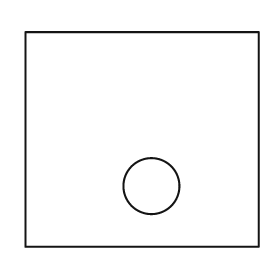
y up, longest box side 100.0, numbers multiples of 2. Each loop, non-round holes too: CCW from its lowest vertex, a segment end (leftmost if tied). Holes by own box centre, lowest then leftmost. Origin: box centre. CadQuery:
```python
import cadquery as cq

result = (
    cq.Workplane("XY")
    .moveTo(-50.0, -46.0)
    .lineTo(50.0, -46.0)
    .lineTo(50.0, 46.0)
    .lineTo(-50.0, 46.0)
    .close()
    .moveTo(4.0, -20.0)
    .circle(12.0)
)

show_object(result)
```